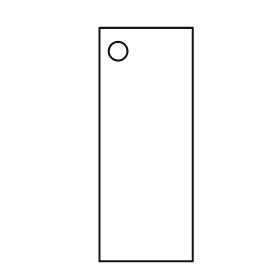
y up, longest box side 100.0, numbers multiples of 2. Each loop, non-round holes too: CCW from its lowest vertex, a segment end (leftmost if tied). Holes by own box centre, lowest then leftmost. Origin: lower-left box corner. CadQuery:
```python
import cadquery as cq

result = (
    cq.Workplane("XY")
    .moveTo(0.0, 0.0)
    .lineTo(40.0, 0.0)
    .lineTo(40.0, 100.0)
    .lineTo(0.0, 100.0)
    .close()
    .moveTo(8.0, 90.0)
    .circle(4.0)
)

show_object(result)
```